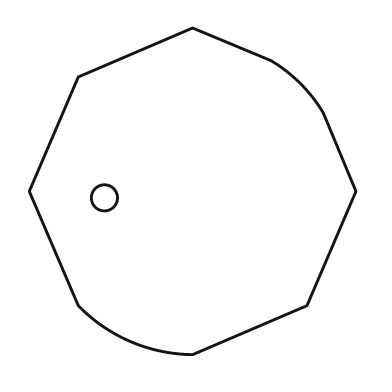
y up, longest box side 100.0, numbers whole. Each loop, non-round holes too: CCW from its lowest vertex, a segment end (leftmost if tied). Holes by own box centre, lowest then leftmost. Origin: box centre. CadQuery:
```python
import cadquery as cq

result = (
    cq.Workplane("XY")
    .moveTo(0.0, -50.0)
    .lineTo(35.0, -35.0)
    .lineTo(50.0, 0.0)
    .lineTo(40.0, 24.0)
    .threePointArc((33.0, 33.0), (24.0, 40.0))
    .lineTo(0.0, 50.0)
    .lineTo(-35.0, 35.0)
    .lineTo(-50.0, 0.0)
    .lineTo(-35.0, -35.0)
    .threePointArc((-19.0, -46.0), (0.0, -50.0))
    .close()
    .moveTo(-27.0, -2.0)
    .circle(4.0)
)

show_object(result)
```